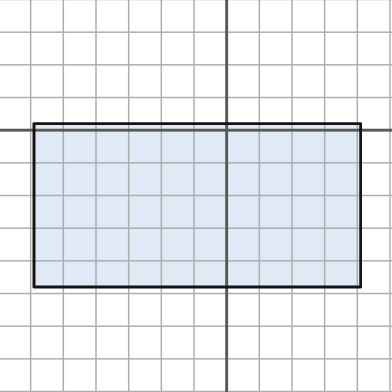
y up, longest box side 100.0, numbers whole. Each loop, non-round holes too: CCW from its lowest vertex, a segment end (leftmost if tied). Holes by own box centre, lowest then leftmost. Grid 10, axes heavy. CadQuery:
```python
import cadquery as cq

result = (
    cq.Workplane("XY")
    .moveTo(-59.0, -48.0)
    .lineTo(41.0, -48.0)
    .lineTo(41.0, 2.0)
    .lineTo(-59.0, 2.0)
    .close()
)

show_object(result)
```